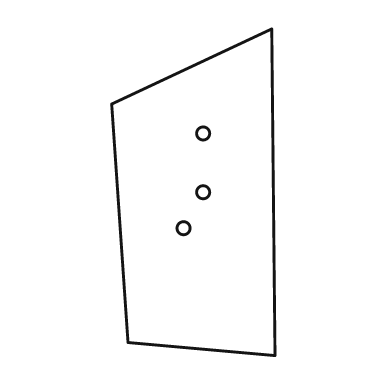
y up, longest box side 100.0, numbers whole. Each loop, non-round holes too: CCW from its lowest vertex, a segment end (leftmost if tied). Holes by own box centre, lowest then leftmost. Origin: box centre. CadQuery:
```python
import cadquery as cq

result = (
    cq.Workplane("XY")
    .moveTo(25.0, -50.0)
    .lineTo(24.0, 50.0)
    .lineTo(-25.0, 27.0)
    .lineTo(-20.0, -46.0)
    .close()
    .moveTo(-3.0, -11.0)
    .circle(2.0)
    .moveTo(3.0, 0.0)
    .circle(2.0)
    .moveTo(3.0, 18.0)
    .circle(2.0)
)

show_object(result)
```